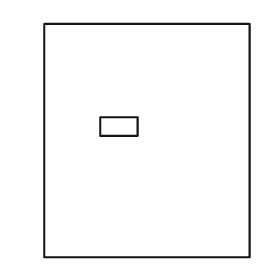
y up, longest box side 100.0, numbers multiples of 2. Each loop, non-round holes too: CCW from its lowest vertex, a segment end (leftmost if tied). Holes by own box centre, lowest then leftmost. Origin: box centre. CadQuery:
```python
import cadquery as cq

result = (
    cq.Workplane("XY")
    .moveTo(-44.0, -50.0)
    .lineTo(44.0, -50.0)
    .lineTo(44.0, 50.0)
    .lineTo(-44.0, 50.0)
    .close()
    .moveTo(-20.0, 2.0)
    .lineTo(-4.0, 2.0)
    .lineTo(-4.0, 10.0)
    .lineTo(-20.0, 10.0)
    .close()
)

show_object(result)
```